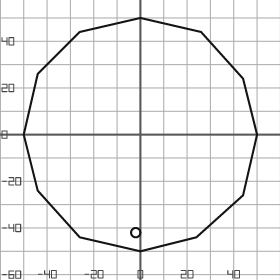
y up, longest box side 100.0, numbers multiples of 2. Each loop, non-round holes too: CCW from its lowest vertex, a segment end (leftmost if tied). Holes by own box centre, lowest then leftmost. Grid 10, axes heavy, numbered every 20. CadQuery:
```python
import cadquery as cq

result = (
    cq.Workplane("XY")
    .moveTo(0.0, -50.0)
    .lineTo(24.0, -44.0)
    .lineTo(44.0, -26.0)
    .lineTo(50.0, 0.0)
    .lineTo(44.0, 24.0)
    .lineTo(26.0, 44.0)
    .lineTo(0.0, 50.0)
    .lineTo(-26.0, 44.0)
    .lineTo(-44.0, 26.0)
    .lineTo(-50.0, 0.0)
    .lineTo(-44.0, -24.0)
    .lineTo(-26.0, -44.0)
    .close()
    .moveTo(-2.0, -42.0)
    .circle(2.0)
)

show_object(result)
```